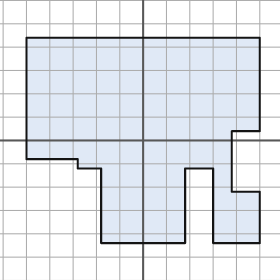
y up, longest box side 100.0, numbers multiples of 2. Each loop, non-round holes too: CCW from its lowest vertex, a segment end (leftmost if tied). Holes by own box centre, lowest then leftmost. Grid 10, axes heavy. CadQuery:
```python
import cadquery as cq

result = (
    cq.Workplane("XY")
    .moveTo(-18.0, -44.0)
    .lineTo(18.0, -44.0)
    .lineTo(18.0, -12.0)
    .lineTo(30.0, -12.0)
    .lineTo(30.0, -44.0)
    .lineTo(50.0, -44.0)
    .lineTo(50.0, -22.0)
    .lineTo(38.0, -22.0)
    .lineTo(38.0, 4.0)
    .lineTo(50.0, 4.0)
    .lineTo(50.0, 44.0)
    .lineTo(-50.0, 44.0)
    .lineTo(-50.0, -8.0)
    .lineTo(-28.0, -8.0)
    .lineTo(-28.0, -12.0)
    .lineTo(-18.0, -12.0)
    .close()
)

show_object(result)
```